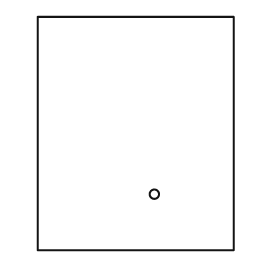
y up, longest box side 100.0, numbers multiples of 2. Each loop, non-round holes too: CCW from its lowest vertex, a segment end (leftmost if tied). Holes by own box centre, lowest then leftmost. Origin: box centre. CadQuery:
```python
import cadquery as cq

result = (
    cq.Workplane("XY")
    .moveTo(-42.0, -50.0)
    .lineTo(42.0, -50.0)
    .lineTo(42.0, 50.0)
    .lineTo(-42.0, 50.0)
    .close()
    .moveTo(8.0, -26.0)
    .circle(2.0)
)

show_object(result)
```